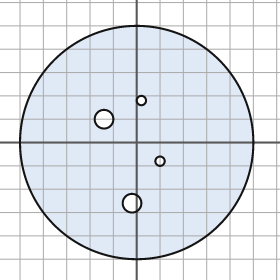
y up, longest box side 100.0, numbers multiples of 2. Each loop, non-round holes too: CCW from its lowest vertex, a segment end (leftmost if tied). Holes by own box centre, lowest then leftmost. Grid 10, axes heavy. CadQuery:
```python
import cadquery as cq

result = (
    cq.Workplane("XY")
    .moveTo(0.0, 0.0)
    .circle(50.0)
    .moveTo(-2.0, -26.0)
    .circle(4.0)
    .moveTo(10.0, -8.0)
    .circle(2.0)
    .moveTo(-14.0, 10.0)
    .circle(4.0)
    .moveTo(2.0, 18.0)
    .circle(2.0)
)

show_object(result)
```